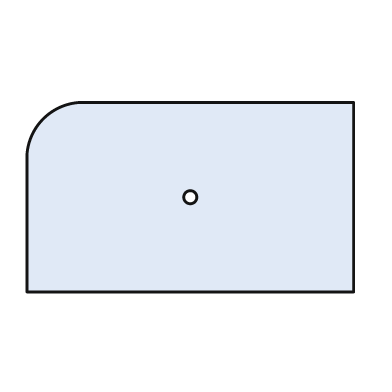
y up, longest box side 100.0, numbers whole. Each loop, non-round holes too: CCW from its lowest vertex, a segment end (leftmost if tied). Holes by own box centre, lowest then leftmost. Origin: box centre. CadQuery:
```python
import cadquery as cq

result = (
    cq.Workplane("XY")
    .moveTo(-50.0, -29.0)
    .lineTo(50.0, -29.0)
    .lineTo(50.0, 29.0)
    .lineTo(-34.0, 29.0)
    .threePointArc((-45.0, 24.0), (-50.0, 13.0))
    .close()
    .moveTo(0.0, 0.0)
    .circle(2.0)
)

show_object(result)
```